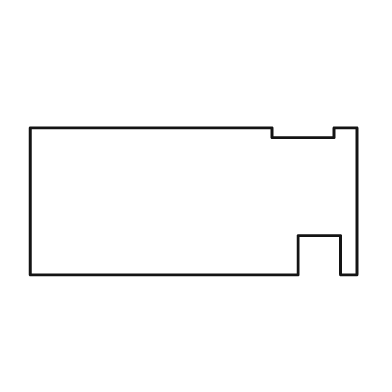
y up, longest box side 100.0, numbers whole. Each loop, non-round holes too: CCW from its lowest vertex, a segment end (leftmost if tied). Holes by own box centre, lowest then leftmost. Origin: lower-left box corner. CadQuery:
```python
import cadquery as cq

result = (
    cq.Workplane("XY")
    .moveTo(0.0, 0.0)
    .lineTo(82.0, 0.0)
    .lineTo(82.0, 12.0)
    .lineTo(95.0, 12.0)
    .lineTo(95.0, 0.0)
    .lineTo(100.0, 0.0)
    .lineTo(100.0, 45.0)
    .lineTo(93.0, 45.0)
    .lineTo(93.0, 42.0)
    .lineTo(74.0, 42.0)
    .lineTo(74.0, 45.0)
    .lineTo(0.0, 45.0)
    .close()
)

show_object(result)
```